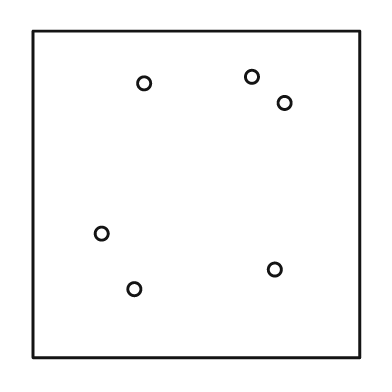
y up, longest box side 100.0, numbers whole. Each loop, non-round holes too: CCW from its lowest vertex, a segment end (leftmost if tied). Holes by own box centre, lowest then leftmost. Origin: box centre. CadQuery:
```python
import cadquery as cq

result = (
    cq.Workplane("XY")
    .moveTo(-50.0, -50.0)
    .lineTo(50.0, -50.0)
    .lineTo(50.0, 50.0)
    .lineTo(-50.0, 50.0)
    .close()
    .moveTo(-19.0, -29.0)
    .circle(2.0)
    .moveTo(24.0, -23.0)
    .circle(2.0)
    .moveTo(-29.0, -12.0)
    .circle(2.0)
    .moveTo(27.0, 28.0)
    .circle(2.0)
    .moveTo(-16.0, 34.0)
    .circle(2.0)
    .moveTo(17.0, 36.0)
    .circle(2.0)
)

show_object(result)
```